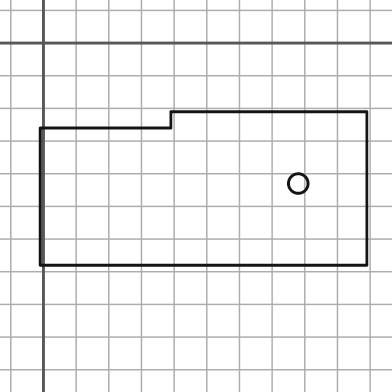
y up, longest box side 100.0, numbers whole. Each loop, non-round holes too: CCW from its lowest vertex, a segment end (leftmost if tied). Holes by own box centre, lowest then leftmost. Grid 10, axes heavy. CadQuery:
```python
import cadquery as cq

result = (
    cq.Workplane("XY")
    .moveTo(-1.0, -68.0)
    .lineTo(99.0, -68.0)
    .lineTo(99.0, -21.0)
    .lineTo(39.0, -21.0)
    .lineTo(39.0, -26.0)
    .lineTo(-1.0, -26.0)
    .close()
    .moveTo(78.0, -43.0)
    .circle(3.0)
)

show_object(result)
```